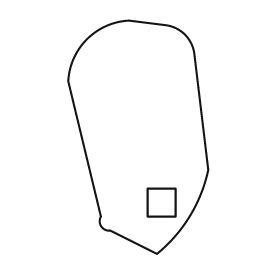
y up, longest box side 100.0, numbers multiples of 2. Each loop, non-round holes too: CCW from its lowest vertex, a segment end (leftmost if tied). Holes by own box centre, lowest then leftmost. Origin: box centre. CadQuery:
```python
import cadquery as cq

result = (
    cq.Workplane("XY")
    .moveTo(8.0, -50.0)
    .threePointArc((22.0, -34.0), (30.0, -14.0))
    .lineTo(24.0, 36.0)
    .threePointArc((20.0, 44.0), (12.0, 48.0))
    .lineTo(-4.0, 50.0)
    .threePointArc((-22.0, 42.0), (-30.0, 24.0))
    .lineTo(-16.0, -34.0)
    .threePointArc((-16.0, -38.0), (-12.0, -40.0))
    .close()
    .moveTo(4.0, -34.0)
    .lineTo(16.0, -34.0)
    .lineTo(16.0, -22.0)
    .lineTo(4.0, -22.0)
    .close()
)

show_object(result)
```